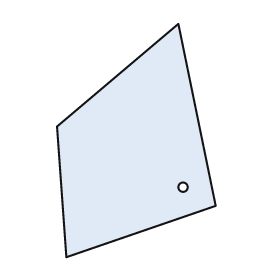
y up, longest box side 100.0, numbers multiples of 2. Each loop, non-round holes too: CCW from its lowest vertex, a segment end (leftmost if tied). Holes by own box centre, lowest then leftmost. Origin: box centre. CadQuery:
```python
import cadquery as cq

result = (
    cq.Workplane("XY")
    .moveTo(-30.0, -50.0)
    .lineTo(34.0, -28.0)
    .lineTo(18.0, 50.0)
    .lineTo(-34.0, 6.0)
    .close()
    .moveTo(20.0, -20.0)
    .circle(2.0)
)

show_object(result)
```